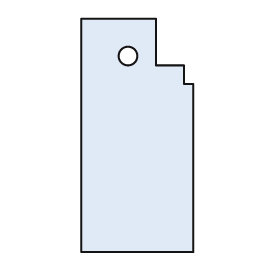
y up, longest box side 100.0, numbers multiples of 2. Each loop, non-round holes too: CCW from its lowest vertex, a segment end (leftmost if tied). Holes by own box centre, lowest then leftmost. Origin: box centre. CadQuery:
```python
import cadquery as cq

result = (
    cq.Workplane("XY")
    .moveTo(-24.0, -50.0)
    .lineTo(24.0, -50.0)
    .lineTo(24.0, 22.0)
    .lineTo(20.0, 22.0)
    .lineTo(20.0, 30.0)
    .lineTo(8.0, 30.0)
    .lineTo(8.0, 50.0)
    .lineTo(-24.0, 50.0)
    .close()
    .moveTo(-4.0, 34.0)
    .circle(4.0)
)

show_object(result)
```